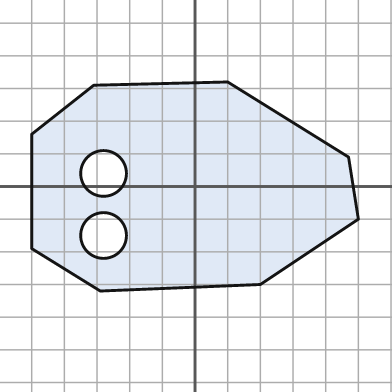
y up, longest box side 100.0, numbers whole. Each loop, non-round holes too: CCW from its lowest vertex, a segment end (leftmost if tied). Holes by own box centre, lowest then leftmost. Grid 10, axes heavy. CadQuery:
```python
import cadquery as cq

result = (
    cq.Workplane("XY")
    .moveTo(-29.0, -32.0)
    .lineTo(20.0, -30.0)
    .lineTo(50.0, -10.0)
    .lineTo(47.0, 9.0)
    .lineTo(10.0, 32.0)
    .lineTo(-31.0, 31.0)
    .lineTo(-50.0, 16.0)
    .lineTo(-50.0, -19.0)
    .close()
    .moveTo(-28.0, -15.0)
    .circle(7.0)
    .moveTo(-28.0, 4.0)
    .circle(7.0)
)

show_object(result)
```